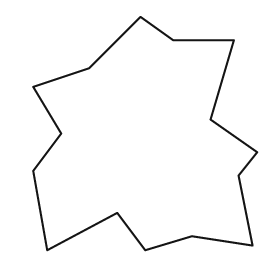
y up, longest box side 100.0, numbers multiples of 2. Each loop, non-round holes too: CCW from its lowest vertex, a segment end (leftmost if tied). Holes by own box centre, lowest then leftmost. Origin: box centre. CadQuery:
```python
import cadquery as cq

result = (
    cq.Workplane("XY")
    .moveTo(-42.0, -50.0)
    .lineTo(-12.0, -34.0)
    .lineTo(0.0, -50.0)
    .lineTo(20.0, -44.0)
    .lineTo(46.0, -48.0)
    .lineTo(40.0, -18.0)
    .lineTo(48.0, -8.0)
    .lineTo(28.0, 6.0)
    .lineTo(38.0, 40.0)
    .lineTo(12.0, 40.0)
    .lineTo(-2.0, 50.0)
    .lineTo(-24.0, 28.0)
    .lineTo(-48.0, 20.0)
    .lineTo(-36.0, 0.0)
    .lineTo(-48.0, -16.0)
    .close()
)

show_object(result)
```